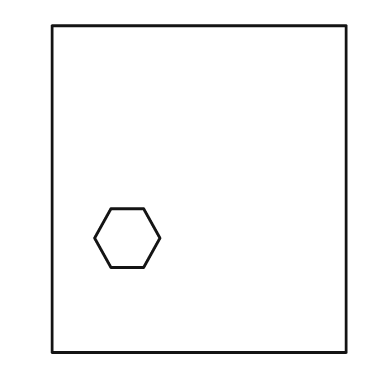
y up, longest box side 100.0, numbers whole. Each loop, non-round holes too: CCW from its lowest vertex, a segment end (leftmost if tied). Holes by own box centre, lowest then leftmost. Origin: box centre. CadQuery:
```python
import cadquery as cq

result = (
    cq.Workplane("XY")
    .moveTo(-45.0, -50.0)
    .lineTo(45.0, -50.0)
    .lineTo(45.0, 50.0)
    .lineTo(-45.0, 50.0)
    .close()
    .moveTo(-27.0, -24.0)
    .lineTo(-17.0, -24.0)
    .lineTo(-12.0, -15.0)
    .lineTo(-17.0, -6.0)
    .lineTo(-27.0, -6.0)
    .lineTo(-32.0, -15.0)
    .close()
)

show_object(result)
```